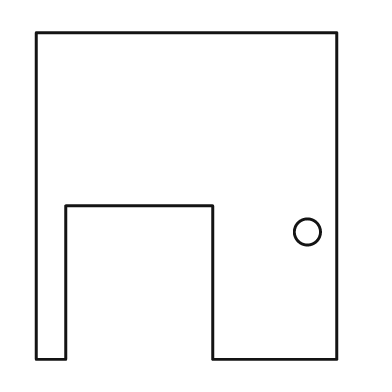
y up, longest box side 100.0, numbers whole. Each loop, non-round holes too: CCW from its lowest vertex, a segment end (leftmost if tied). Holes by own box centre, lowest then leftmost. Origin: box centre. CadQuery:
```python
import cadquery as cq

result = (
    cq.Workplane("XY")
    .moveTo(-46.0, -50.0)
    .lineTo(-37.0, -50.0)
    .lineTo(-37.0, -3.0)
    .lineTo(8.0, -3.0)
    .lineTo(8.0, -50.0)
    .lineTo(46.0, -50.0)
    .lineTo(46.0, 50.0)
    .lineTo(-46.0, 50.0)
    .close()
    .moveTo(37.0, -11.0)
    .circle(4.0)
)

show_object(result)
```